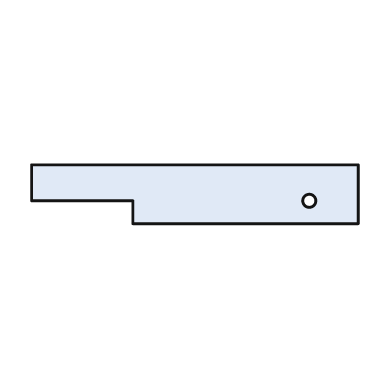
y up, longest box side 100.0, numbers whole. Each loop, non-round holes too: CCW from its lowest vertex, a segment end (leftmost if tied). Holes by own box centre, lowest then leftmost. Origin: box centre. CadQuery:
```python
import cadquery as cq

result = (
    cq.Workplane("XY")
    .moveTo(-19.0, -9.0)
    .lineTo(50.0, -9.0)
    .lineTo(50.0, 9.0)
    .lineTo(-50.0, 9.0)
    .lineTo(-50.0, -2.0)
    .lineTo(-19.0, -2.0)
    .close()
    .moveTo(35.0, -2.0)
    .circle(2.0)
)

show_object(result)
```